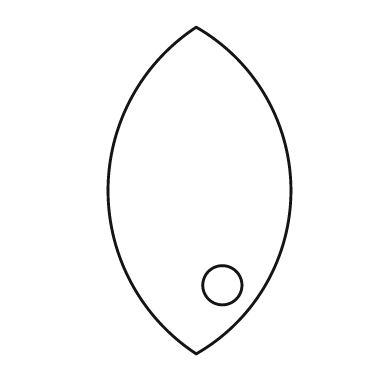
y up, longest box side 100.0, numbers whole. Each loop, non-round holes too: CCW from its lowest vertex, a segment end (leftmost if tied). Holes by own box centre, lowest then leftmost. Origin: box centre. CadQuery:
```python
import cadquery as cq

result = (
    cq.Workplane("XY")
    .moveTo(-1.0, -50.0)
    .threePointArc((28.0, 0.0), (-1.0, 50.0))
    .threePointArc((-28.0, 0.0), (-1.0, -50.0))
    .close()
    .moveTo(7.0, -29.0)
    .circle(6.0)
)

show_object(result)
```